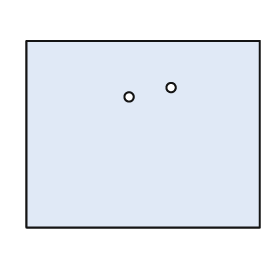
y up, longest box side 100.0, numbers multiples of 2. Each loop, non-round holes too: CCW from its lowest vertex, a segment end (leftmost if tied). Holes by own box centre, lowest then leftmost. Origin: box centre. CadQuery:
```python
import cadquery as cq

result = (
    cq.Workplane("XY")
    .moveTo(-50.0, -40.0)
    .lineTo(50.0, -40.0)
    .lineTo(50.0, 40.0)
    .lineTo(-50.0, 40.0)
    .close()
    .moveTo(-6.0, 16.0)
    .circle(2.0)
    .moveTo(12.0, 20.0)
    .circle(2.0)
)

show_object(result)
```